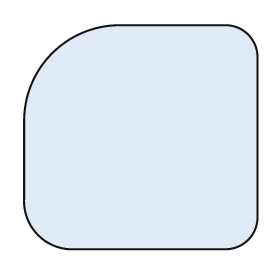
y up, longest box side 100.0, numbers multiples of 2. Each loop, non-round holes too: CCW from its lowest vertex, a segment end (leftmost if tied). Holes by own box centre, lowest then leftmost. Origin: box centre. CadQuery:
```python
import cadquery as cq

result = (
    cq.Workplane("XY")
    .moveTo(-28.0, -48.0)
    .lineTo(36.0, -48.0)
    .threePointArc((46.0, -44.0), (50.0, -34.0))
    .lineTo(50.0, 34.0)
    .threePointArc((46.0, 44.0), (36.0, 48.0))
    .lineTo(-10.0, 48.0)
    .threePointArc((-38.0, 36.0), (-50.0, 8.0))
    .lineTo(-50.0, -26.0)
    .threePointArc((-44.0, -42.0), (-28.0, -48.0))
    .close()
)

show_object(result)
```